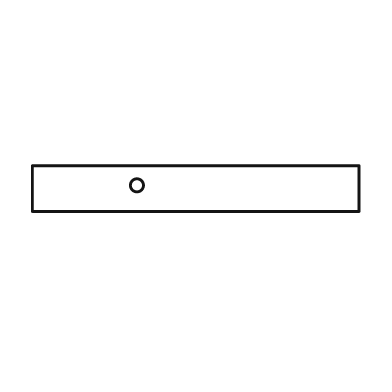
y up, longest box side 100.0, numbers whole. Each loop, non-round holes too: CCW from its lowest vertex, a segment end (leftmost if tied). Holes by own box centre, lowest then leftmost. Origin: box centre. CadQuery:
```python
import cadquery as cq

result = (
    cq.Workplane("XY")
    .moveTo(-50.0, -7.0)
    .lineTo(50.0, -7.0)
    .lineTo(50.0, 7.0)
    .lineTo(-50.0, 7.0)
    .close()
    .moveTo(-18.0, 1.0)
    .circle(2.0)
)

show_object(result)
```